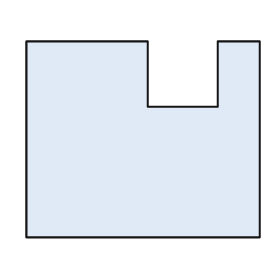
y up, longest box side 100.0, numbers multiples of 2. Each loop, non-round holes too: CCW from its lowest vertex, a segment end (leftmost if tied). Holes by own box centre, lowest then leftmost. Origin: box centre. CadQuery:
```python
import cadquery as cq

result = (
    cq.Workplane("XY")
    .moveTo(-50.0, -42.0)
    .lineTo(50.0, -42.0)
    .lineTo(50.0, 42.0)
    .lineTo(32.0, 42.0)
    .lineTo(32.0, 14.0)
    .lineTo(2.0, 14.0)
    .lineTo(2.0, 42.0)
    .lineTo(-50.0, 42.0)
    .close()
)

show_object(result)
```